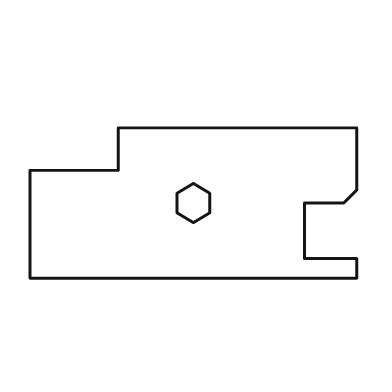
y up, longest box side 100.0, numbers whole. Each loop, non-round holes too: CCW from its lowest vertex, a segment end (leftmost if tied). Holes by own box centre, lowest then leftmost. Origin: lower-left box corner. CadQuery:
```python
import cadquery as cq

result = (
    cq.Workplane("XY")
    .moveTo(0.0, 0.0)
    .lineTo(100.0, 0.0)
    .lineTo(100.0, 6.0)
    .lineTo(84.0, 6.0)
    .lineTo(84.0, 23.0)
    .lineTo(96.0, 23.0)
    .lineTo(100.0, 27.0)
    .lineTo(100.0, 46.0)
    .lineTo(27.0, 46.0)
    .lineTo(27.0, 33.0)
    .lineTo(0.0, 33.0)
    .close()
    .moveTo(50.0, 17.0)
    .lineTo(55.0, 20.0)
    .lineTo(55.0, 26.0)
    .lineTo(50.0, 29.0)
    .lineTo(45.0, 26.0)
    .lineTo(45.0, 20.0)
    .close()
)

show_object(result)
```